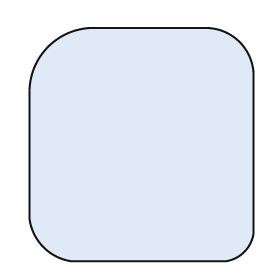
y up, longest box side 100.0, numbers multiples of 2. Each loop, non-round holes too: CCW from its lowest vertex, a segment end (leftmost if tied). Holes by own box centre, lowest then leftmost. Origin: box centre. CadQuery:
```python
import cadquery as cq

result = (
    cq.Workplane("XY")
    .moveTo(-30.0, -50.0)
    .lineTo(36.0, -50.0)
    .threePointArc((44.0, -46.0), (48.0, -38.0))
    .lineTo(48.0, 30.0)
    .threePointArc((42.0, 44.0), (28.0, 50.0))
    .lineTo(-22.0, 50.0)
    .threePointArc((-40.0, 42.0), (-48.0, 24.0))
    .lineTo(-48.0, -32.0)
    .threePointArc((-42.0, -44.0), (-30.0, -50.0))
    .close()
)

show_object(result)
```